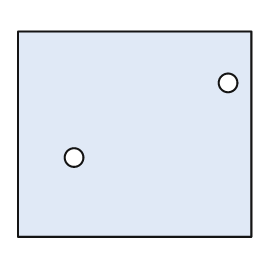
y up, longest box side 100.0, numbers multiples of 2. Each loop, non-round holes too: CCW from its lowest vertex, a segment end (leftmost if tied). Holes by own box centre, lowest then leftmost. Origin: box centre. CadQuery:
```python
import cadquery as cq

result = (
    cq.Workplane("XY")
    .moveTo(-50.0, -44.0)
    .lineTo(50.0, -44.0)
    .lineTo(50.0, 44.0)
    .lineTo(-50.0, 44.0)
    .close()
    .moveTo(-26.0, -10.0)
    .circle(4.0)
    .moveTo(40.0, 22.0)
    .circle(4.0)
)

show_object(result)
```